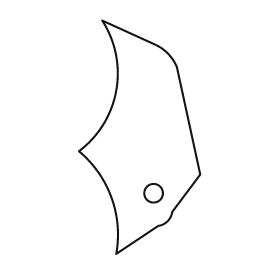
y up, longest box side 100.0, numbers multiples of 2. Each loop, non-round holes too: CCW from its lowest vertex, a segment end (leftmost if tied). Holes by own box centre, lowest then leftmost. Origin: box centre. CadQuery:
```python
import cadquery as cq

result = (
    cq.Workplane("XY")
    .moveTo(-10.0, -50.0)
    .lineTo(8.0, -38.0)
    .threePointArc((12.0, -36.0), (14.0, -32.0))
    .lineTo(26.0, -16.0)
    .lineTo(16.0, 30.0)
    .threePointArc((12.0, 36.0), (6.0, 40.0))
    .lineTo(-16.0, 50.0)
    .threePointArc((-10.0, 20.0), (-26.0, -6.0))
    .threePointArc((-12.0, -26.0), (-10.0, -50.0))
    .close()
    .moveTo(6.0, -24.0)
    .circle(4.0)
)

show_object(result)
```